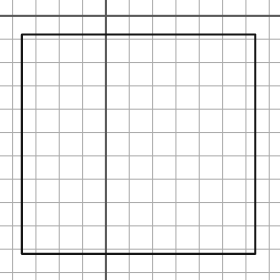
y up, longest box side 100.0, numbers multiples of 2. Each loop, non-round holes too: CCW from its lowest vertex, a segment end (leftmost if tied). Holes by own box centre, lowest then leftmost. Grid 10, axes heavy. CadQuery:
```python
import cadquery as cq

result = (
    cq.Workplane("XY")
    .moveTo(-36.0, -102.0)
    .lineTo(64.0, -102.0)
    .lineTo(64.0, -8.0)
    .lineTo(-36.0, -8.0)
    .close()
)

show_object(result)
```